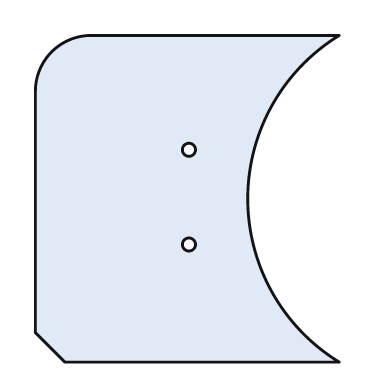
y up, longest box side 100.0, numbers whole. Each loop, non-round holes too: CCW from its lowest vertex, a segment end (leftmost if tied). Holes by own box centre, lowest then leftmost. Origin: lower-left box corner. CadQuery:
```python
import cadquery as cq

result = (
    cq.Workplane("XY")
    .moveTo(9.0, 0.0)
    .lineTo(93.0, 0.0)
    .threePointArc((65.0, 50.0), (93.0, 100.0))
    .lineTo(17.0, 100.0)
    .threePointArc((5.0, 95.0), (0.0, 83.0))
    .lineTo(0.0, 9.0)
    .close()
    .moveTo(47.0, 36.0)
    .circle(2.0)
    .moveTo(47.0, 65.0)
    .circle(2.0)
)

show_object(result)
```